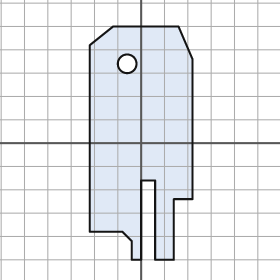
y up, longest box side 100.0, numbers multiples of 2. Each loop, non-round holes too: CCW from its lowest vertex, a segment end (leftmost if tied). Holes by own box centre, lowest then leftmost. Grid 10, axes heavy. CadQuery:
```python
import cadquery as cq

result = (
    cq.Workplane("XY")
    .moveTo(-4.0, -50.0)
    .lineTo(0.0, -50.0)
    .lineTo(0.0, -16.0)
    .lineTo(6.0, -16.0)
    .lineTo(6.0, -50.0)
    .lineTo(14.0, -50.0)
    .lineTo(14.0, -24.0)
    .lineTo(22.0, -24.0)
    .lineTo(22.0, 36.0)
    .lineTo(16.0, 50.0)
    .lineTo(-12.0, 50.0)
    .lineTo(-22.0, 42.0)
    .lineTo(-22.0, -38.0)
    .lineTo(-8.0, -38.0)
    .lineTo(-4.0, -42.0)
    .close()
    .moveTo(-6.0, 34.0)
    .circle(4.0)
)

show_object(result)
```